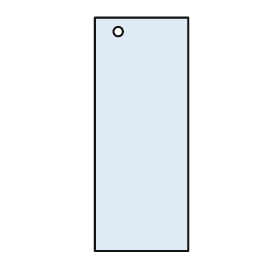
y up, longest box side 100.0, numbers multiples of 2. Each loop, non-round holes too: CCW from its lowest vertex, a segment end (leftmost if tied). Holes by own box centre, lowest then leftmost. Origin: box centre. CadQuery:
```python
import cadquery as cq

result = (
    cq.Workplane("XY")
    .moveTo(-20.0, -50.0)
    .lineTo(20.0, -50.0)
    .lineTo(20.0, 50.0)
    .lineTo(-20.0, 50.0)
    .close()
    .moveTo(-10.0, 44.0)
    .circle(2.0)
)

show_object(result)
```